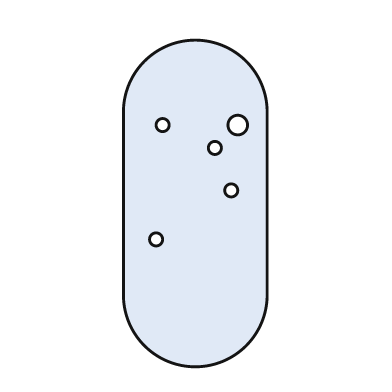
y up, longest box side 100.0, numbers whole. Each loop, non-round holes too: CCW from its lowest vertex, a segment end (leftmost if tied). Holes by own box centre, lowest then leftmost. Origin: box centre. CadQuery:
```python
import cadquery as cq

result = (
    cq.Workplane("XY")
    .moveTo(-22.0, -28.0)
    .threePointArc((0.0, -50.0), (22.0, -28.0))
    .lineTo(22.0, 28.0)
    .threePointArc((0.0, 50.0), (-22.0, 28.0))
    .close()
    .moveTo(-12.0, -11.0)
    .circle(2.0)
    .moveTo(11.0, 4.0)
    .circle(2.0)
    .moveTo(6.0, 17.0)
    .circle(2.0)
    .moveTo(-10.0, 24.0)
    .circle(2.0)
    .moveTo(13.0, 24.0)
    .circle(3.0)
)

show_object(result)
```